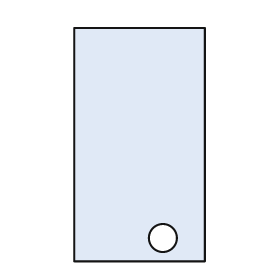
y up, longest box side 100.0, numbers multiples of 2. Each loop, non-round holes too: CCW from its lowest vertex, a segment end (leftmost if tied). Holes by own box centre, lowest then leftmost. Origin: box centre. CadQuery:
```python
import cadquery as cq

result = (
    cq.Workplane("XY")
    .moveTo(-28.0, -50.0)
    .lineTo(28.0, -50.0)
    .lineTo(28.0, 50.0)
    .lineTo(-28.0, 50.0)
    .close()
    .moveTo(10.0, -40.0)
    .circle(6.0)
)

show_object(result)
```